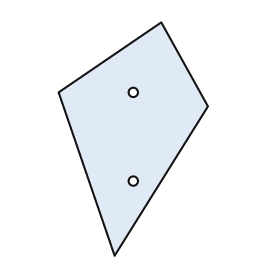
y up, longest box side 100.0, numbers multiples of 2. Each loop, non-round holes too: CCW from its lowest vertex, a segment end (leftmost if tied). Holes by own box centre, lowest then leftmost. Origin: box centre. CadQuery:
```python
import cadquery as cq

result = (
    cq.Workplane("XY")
    .moveTo(-8.0, -50.0)
    .lineTo(32.0, 14.0)
    .lineTo(12.0, 50.0)
    .lineTo(-32.0, 20.0)
    .close()
    .moveTo(0.0, -18.0)
    .circle(2.0)
    .moveTo(0.0, 20.0)
    .circle(2.0)
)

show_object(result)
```